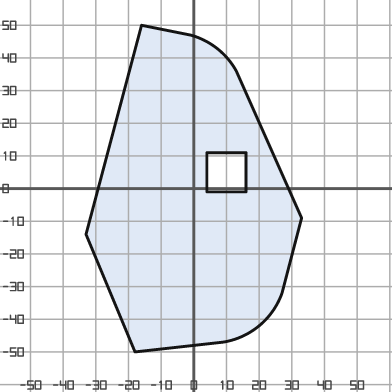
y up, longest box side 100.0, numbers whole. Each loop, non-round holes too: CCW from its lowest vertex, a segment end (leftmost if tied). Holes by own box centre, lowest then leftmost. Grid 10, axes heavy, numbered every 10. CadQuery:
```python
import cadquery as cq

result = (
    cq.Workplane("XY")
    .moveTo(-18.0, -50.0)
    .lineTo(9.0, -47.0)
    .threePointArc((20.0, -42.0), (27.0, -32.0))
    .lineTo(33.0, -9.0)
    .lineTo(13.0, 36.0)
    .threePointArc((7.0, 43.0), (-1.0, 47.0))
    .lineTo(-16.0, 50.0)
    .lineTo(-33.0, -14.0)
    .close()
    .moveTo(4.0, -1.0)
    .lineTo(16.0, -1.0)
    .lineTo(16.0, 11.0)
    .lineTo(4.0, 11.0)
    .close()
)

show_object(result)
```